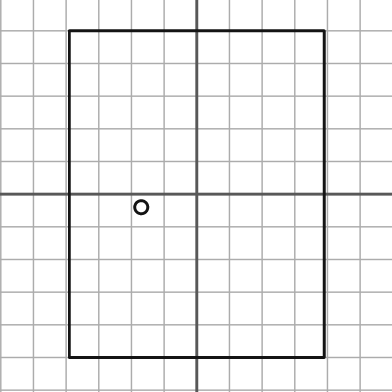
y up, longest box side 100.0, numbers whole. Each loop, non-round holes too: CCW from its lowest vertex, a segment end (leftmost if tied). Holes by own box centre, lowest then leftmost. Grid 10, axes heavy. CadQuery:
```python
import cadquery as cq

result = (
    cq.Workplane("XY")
    .moveTo(-39.0, -50.0)
    .lineTo(39.0, -50.0)
    .lineTo(39.0, 50.0)
    .lineTo(-39.0, 50.0)
    .close()
    .moveTo(-17.0, -4.0)
    .circle(2.0)
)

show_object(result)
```